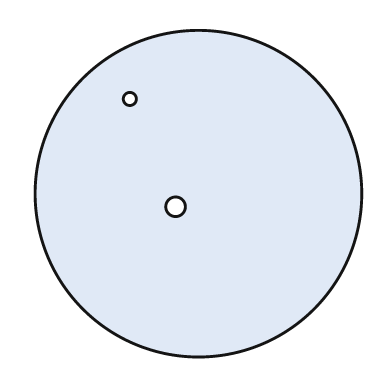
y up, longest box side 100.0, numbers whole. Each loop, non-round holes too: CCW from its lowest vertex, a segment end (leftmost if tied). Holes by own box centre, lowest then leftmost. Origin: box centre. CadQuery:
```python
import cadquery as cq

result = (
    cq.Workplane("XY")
    .moveTo(0.0, 0.0)
    .circle(50.0)
    .moveTo(-7.0, -4.0)
    .circle(3.0)
    .moveTo(-21.0, 29.0)
    .circle(2.0)
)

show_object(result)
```